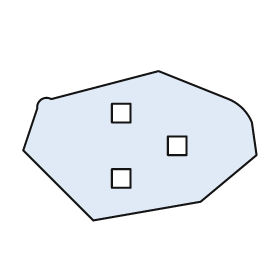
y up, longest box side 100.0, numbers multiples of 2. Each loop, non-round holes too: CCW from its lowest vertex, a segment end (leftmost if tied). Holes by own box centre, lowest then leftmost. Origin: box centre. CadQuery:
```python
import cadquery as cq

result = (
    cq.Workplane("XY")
    .moveTo(-20.0, -32.0)
    .lineTo(26.0, -24.0)
    .lineTo(50.0, -4.0)
    .lineTo(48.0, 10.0)
    .threePointArc((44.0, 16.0), (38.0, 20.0))
    .lineTo(8.0, 32.0)
    .lineTo(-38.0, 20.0)
    .threePointArc((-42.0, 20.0), (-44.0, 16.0))
    .lineTo(-50.0, -2.0)
    .close()
    .moveTo(-12.0, -18.0)
    .lineTo(-4.0, -18.0)
    .lineTo(-4.0, -10.0)
    .lineTo(-12.0, -10.0)
    .close()
    .moveTo(12.0, -4.0)
    .lineTo(20.0, -4.0)
    .lineTo(20.0, 4.0)
    .lineTo(12.0, 4.0)
    .close()
    .moveTo(-12.0, 10.0)
    .lineTo(-4.0, 10.0)
    .lineTo(-4.0, 18.0)
    .lineTo(-12.0, 18.0)
    .close()
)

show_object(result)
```